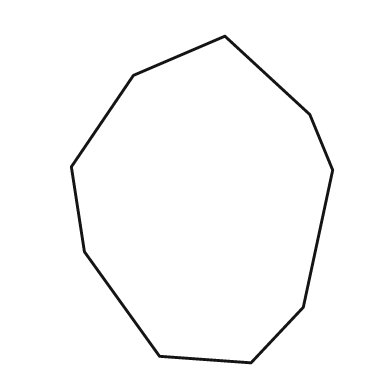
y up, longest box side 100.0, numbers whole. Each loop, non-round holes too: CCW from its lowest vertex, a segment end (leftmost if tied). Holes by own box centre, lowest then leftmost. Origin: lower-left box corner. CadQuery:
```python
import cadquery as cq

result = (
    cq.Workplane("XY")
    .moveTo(55.0, 0.0)
    .lineTo(71.0, 17.0)
    .lineTo(80.0, 59.0)
    .lineTo(73.0, 76.0)
    .lineTo(47.0, 100.0)
    .lineTo(19.0, 88.0)
    .lineTo(0.0, 60.0)
    .lineTo(4.0, 34.0)
    .lineTo(27.0, 2.0)
    .close()
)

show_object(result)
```